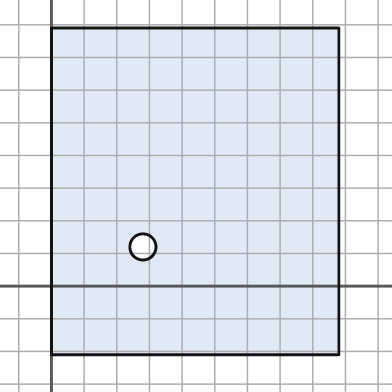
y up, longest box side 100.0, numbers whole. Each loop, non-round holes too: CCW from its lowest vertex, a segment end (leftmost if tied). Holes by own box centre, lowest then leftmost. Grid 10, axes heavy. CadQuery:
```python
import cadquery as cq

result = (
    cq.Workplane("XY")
    .moveTo(0.0, -21.0)
    .lineTo(88.0, -21.0)
    .lineTo(88.0, 79.0)
    .lineTo(0.0, 79.0)
    .close()
    .moveTo(28.0, 12.0)
    .circle(4.0)
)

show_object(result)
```